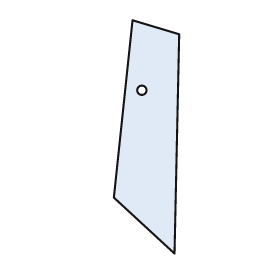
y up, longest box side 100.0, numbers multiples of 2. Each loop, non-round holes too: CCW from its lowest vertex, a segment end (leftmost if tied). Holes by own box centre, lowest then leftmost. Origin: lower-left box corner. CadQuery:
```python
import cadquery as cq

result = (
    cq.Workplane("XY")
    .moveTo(26.0, 0.0)
    .lineTo(28.0, 94.0)
    .lineTo(8.0, 100.0)
    .lineTo(0.0, 24.0)
    .close()
    .moveTo(12.0, 70.0)
    .circle(2.0)
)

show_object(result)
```